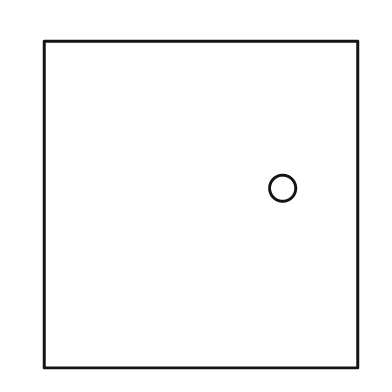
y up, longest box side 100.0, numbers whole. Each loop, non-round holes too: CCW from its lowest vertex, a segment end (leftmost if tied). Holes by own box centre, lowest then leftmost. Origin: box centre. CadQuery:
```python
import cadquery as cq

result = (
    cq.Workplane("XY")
    .moveTo(-48.0, -50.0)
    .lineTo(48.0, -50.0)
    .lineTo(48.0, 50.0)
    .lineTo(-48.0, 50.0)
    .close()
    .moveTo(25.0, 5.0)
    .circle(4.0)
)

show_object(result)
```